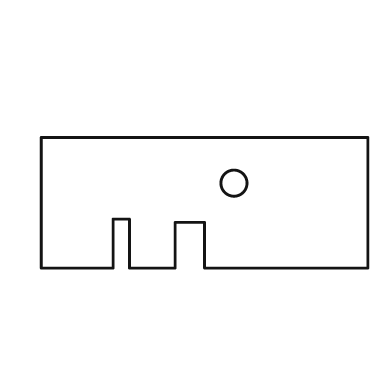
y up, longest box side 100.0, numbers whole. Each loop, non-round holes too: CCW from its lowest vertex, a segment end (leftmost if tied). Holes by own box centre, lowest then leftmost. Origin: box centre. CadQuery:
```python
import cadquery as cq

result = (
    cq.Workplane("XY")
    .moveTo(-50.0, -20.0)
    .lineTo(-28.0, -20.0)
    .lineTo(-28.0, -5.0)
    .lineTo(-23.0, -5.0)
    .lineTo(-23.0, -20.0)
    .lineTo(-9.0, -20.0)
    .lineTo(-9.0, -6.0)
    .lineTo(0.0, -6.0)
    .lineTo(0.0, -20.0)
    .lineTo(50.0, -20.0)
    .lineTo(50.0, 20.0)
    .lineTo(-50.0, 20.0)
    .close()
    .moveTo(9.0, 6.0)
    .circle(4.0)
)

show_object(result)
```